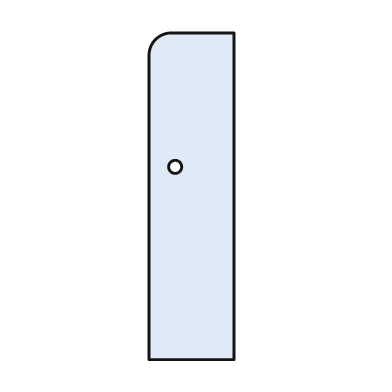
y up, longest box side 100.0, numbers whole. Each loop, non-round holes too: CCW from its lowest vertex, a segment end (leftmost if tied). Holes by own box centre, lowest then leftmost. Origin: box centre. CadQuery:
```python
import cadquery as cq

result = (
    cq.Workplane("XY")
    .moveTo(-13.0, -50.0)
    .lineTo(13.0, -50.0)
    .lineTo(13.0, 50.0)
    .lineTo(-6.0, 50.0)
    .threePointArc((-11.0, 48.0), (-13.0, 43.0))
    .close()
    .moveTo(-5.0, 9.0)
    .circle(2.0)
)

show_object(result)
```